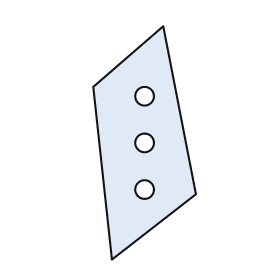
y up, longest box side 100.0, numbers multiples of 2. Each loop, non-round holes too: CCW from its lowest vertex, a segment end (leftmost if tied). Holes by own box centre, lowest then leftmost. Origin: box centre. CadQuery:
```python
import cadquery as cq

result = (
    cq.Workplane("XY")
    .moveTo(-14.0, -50.0)
    .lineTo(22.0, -22.0)
    .lineTo(8.0, 50.0)
    .lineTo(-22.0, 24.0)
    .close()
    .moveTo(0.0, -20.0)
    .circle(4.0)
    .moveTo(0.0, 0.0)
    .circle(4.0)
    .moveTo(0.0, 20.0)
    .circle(4.0)
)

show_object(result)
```